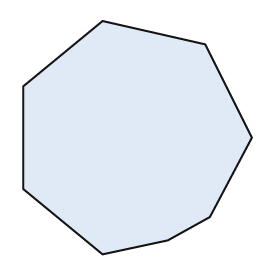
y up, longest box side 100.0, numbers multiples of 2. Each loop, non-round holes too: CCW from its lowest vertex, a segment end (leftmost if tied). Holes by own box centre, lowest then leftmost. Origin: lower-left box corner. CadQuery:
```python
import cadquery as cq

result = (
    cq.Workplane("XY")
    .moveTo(34.0, 0.0)
    .lineTo(62.0, 6.0)
    .lineTo(80.0, 16.0)
    .lineTo(98.0, 50.0)
    .lineTo(78.0, 90.0)
    .lineTo(34.0, 100.0)
    .lineTo(0.0, 72.0)
    .lineTo(0.0, 28.0)
    .close()
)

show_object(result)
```